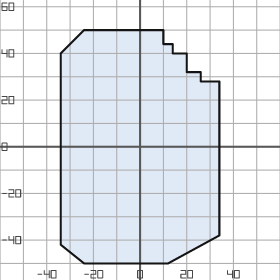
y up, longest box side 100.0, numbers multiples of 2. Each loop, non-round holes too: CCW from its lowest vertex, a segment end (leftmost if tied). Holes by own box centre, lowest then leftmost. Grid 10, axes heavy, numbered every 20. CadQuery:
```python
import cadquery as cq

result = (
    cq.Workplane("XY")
    .moveTo(-24.0, -50.0)
    .lineTo(12.0, -50.0)
    .lineTo(34.0, -38.0)
    .lineTo(34.0, 28.0)
    .lineTo(26.0, 28.0)
    .lineTo(26.0, 32.0)
    .lineTo(20.0, 32.0)
    .lineTo(20.0, 40.0)
    .lineTo(14.0, 40.0)
    .lineTo(14.0, 44.0)
    .lineTo(10.0, 44.0)
    .lineTo(10.0, 50.0)
    .lineTo(-24.0, 50.0)
    .lineTo(-34.0, 40.0)
    .lineTo(-34.0, -42.0)
    .close()
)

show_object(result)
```